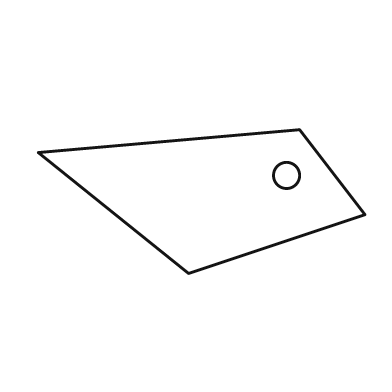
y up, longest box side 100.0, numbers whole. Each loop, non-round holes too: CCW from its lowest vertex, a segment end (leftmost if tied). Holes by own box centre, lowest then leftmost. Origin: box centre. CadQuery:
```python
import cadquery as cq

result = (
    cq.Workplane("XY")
    .moveTo(-4.0, -22.0)
    .lineTo(50.0, -4.0)
    .lineTo(30.0, 22.0)
    .lineTo(-50.0, 15.0)
    .close()
    .moveTo(26.0, 8.0)
    .circle(4.0)
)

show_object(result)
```